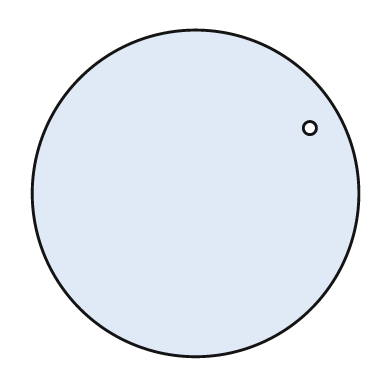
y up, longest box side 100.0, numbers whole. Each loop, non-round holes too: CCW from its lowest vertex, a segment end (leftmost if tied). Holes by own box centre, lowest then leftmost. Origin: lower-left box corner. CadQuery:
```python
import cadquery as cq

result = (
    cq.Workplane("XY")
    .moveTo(50.0, 50.0)
    .circle(50.0)
    .moveTo(85.0, 70.0)
    .circle(2.0)
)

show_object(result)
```